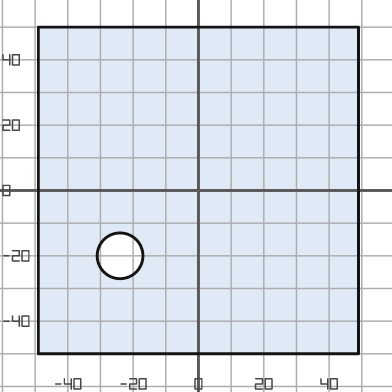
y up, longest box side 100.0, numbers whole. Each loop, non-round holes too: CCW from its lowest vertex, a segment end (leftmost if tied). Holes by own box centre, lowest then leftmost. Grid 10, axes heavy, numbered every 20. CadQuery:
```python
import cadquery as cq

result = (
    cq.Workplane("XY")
    .moveTo(-49.0, -50.0)
    .lineTo(49.0, -50.0)
    .lineTo(49.0, 50.0)
    .lineTo(-49.0, 50.0)
    .close()
    .moveTo(-24.0, -20.0)
    .circle(7.0)
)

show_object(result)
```